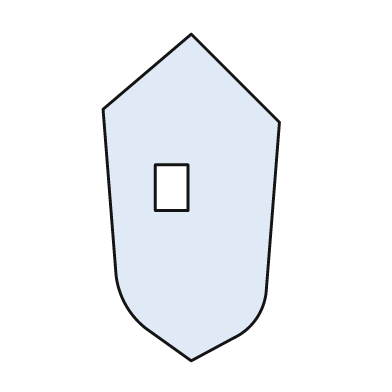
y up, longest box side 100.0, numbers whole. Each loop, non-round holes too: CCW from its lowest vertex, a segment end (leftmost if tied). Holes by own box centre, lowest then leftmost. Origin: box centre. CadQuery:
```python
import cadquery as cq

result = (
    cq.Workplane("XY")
    .moveTo(0.0, -50.0)
    .lineTo(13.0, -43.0)
    .threePointArc((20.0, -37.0), (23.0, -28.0))
    .lineTo(27.0, 23.0)
    .lineTo(0.0, 50.0)
    .lineTo(-27.0, 27.0)
    .lineTo(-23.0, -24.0)
    .threePointArc((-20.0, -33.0), (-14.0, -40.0))
    .close()
    .moveTo(-11.0, -4.0)
    .lineTo(-1.0, -4.0)
    .lineTo(-1.0, 10.0)
    .lineTo(-11.0, 10.0)
    .close()
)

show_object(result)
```